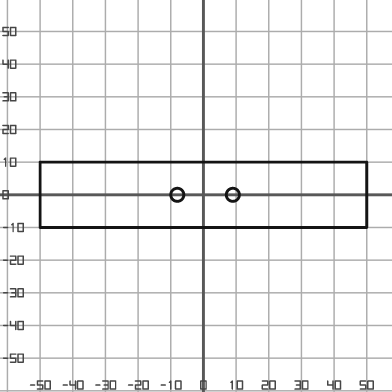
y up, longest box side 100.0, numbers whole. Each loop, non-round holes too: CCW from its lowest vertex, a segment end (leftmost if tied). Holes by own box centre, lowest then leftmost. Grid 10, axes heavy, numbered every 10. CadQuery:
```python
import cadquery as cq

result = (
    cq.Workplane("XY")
    .moveTo(-50.0, -10.0)
    .lineTo(50.0, -10.0)
    .lineTo(50.0, 10.0)
    .lineTo(-50.0, 10.0)
    .close()
    .moveTo(-8.0, 0.0)
    .circle(2.0)
    .moveTo(9.0, 0.0)
    .circle(2.0)
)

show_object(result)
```